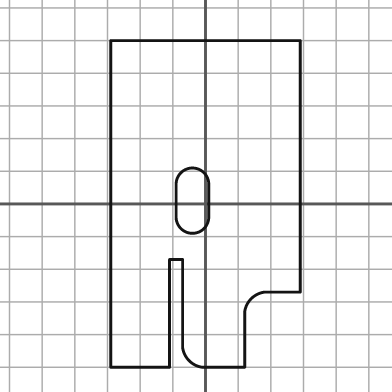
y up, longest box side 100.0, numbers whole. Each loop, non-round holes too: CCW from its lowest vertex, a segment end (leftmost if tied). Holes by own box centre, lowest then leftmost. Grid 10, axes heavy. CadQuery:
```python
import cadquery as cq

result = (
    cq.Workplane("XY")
    .moveTo(-29.0, -50.0)
    .lineTo(-11.0, -50.0)
    .lineTo(-11.0, -17.0)
    .lineTo(-7.0, -17.0)
    .lineTo(-7.0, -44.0)
    .threePointArc((-5.0, -48.0), (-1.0, -50.0))
    .lineTo(12.0, -50.0)
    .lineTo(12.0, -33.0)
    .threePointArc((14.0, -29.0), (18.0, -27.0))
    .lineTo(29.0, -27.0)
    .lineTo(29.0, 50.0)
    .lineTo(-29.0, 50.0)
    .close()
    .moveTo(-9.0, -4.0)
    .threePointArc((-4.0, -9.0), (1.0, -4.0))
    .lineTo(1.0, 6.0)
    .threePointArc((-4.0, 11.0), (-9.0, 6.0))
    .close()
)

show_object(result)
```